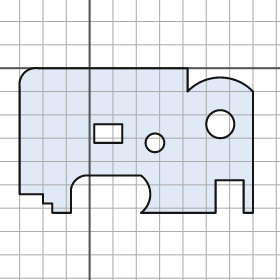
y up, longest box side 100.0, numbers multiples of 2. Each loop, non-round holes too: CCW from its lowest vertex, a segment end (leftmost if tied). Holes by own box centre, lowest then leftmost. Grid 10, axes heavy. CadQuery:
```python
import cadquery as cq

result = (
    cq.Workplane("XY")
    .moveTo(-16.0, -62.0)
    .lineTo(-8.0, -62.0)
    .lineTo(-8.0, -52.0)
    .threePointArc((-6.0, -48.0), (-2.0, -46.0))
    .lineTo(22.0, -46.0)
    .threePointArc((26.0, -54.0), (22.0, -62.0))
    .lineTo(54.0, -62.0)
    .lineTo(54.0, -48.0)
    .lineTo(66.0, -48.0)
    .lineTo(66.0, -62.0)
    .lineTo(70.0, -62.0)
    .lineTo(70.0, -10.0)
    .threePointArc((56.0, -4.0), (42.0, -10.0))
    .lineTo(42.0, 0.0)
    .lineTo(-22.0, 0.0)
    .threePointArc((-28.0, -2.0), (-30.0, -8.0))
    .lineTo(-30.0, -54.0)
    .lineTo(-20.0, -54.0)
    .lineTo(-20.0, -58.0)
    .lineTo(-16.0, -58.0)
    .close()
    .moveTo(28.0, -32.0)
    .circle(4.0)
    .moveTo(2.0, -32.0)
    .lineTo(14.0, -32.0)
    .lineTo(14.0, -24.0)
    .lineTo(2.0, -24.0)
    .close()
    .moveTo(56.0, -24.0)
    .circle(6.0)
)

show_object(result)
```